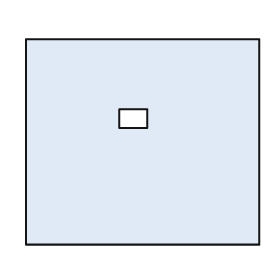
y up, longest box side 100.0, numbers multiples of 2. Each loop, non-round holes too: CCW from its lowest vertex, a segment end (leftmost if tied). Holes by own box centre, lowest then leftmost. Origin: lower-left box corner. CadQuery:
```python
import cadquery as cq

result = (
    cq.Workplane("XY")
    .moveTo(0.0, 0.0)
    .lineTo(100.0, 0.0)
    .lineTo(100.0, 88.0)
    .lineTo(0.0, 88.0)
    .close()
    .moveTo(40.0, 50.0)
    .lineTo(52.0, 50.0)
    .lineTo(52.0, 58.0)
    .lineTo(40.0, 58.0)
    .close()
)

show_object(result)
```